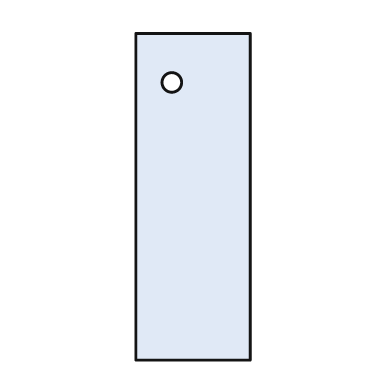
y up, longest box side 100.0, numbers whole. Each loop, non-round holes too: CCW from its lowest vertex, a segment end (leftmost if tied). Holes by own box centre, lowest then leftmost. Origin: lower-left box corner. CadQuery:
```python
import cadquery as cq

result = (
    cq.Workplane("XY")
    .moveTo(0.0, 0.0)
    .lineTo(35.0, 0.0)
    .lineTo(35.0, 100.0)
    .lineTo(0.0, 100.0)
    .close()
    .moveTo(11.0, 85.0)
    .circle(3.0)
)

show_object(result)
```